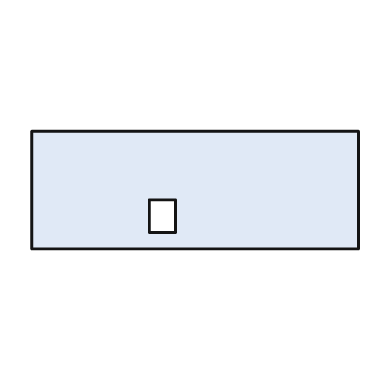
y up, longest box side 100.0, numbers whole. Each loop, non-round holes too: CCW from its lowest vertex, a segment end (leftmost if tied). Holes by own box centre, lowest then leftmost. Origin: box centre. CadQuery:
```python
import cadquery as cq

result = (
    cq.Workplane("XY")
    .moveTo(-50.0, -18.0)
    .lineTo(50.0, -18.0)
    .lineTo(50.0, 18.0)
    .lineTo(-50.0, 18.0)
    .close()
    .moveTo(-14.0, -13.0)
    .lineTo(-6.0, -13.0)
    .lineTo(-6.0, -3.0)
    .lineTo(-14.0, -3.0)
    .close()
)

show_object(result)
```